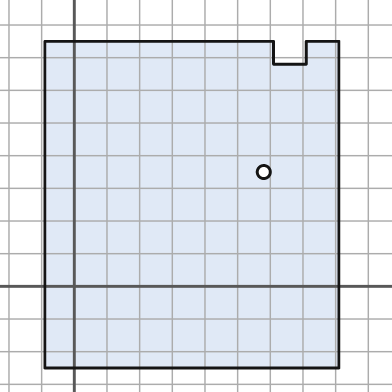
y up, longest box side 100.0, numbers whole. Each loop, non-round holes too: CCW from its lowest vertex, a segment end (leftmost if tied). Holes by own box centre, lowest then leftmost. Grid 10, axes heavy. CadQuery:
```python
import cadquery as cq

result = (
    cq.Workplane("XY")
    .moveTo(-9.0, -25.0)
    .lineTo(81.0, -25.0)
    .lineTo(81.0, 75.0)
    .lineTo(71.0, 75.0)
    .lineTo(71.0, 68.0)
    .lineTo(61.0, 68.0)
    .lineTo(61.0, 75.0)
    .lineTo(-9.0, 75.0)
    .close()
    .moveTo(58.0, 35.0)
    .circle(2.0)
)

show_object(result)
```